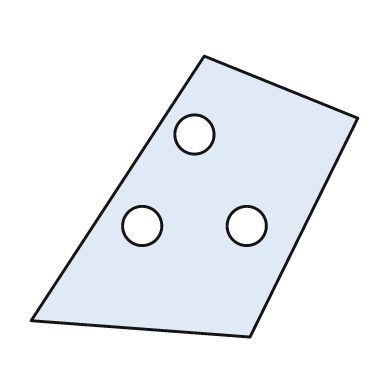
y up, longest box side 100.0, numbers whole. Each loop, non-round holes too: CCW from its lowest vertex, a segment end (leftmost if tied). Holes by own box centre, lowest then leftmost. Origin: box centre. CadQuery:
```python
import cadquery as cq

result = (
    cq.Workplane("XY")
    .moveTo(17.0, -43.0)
    .lineTo(50.0, 24.0)
    .lineTo(3.0, 43.0)
    .lineTo(-50.0, -38.0)
    .close()
    .moveTo(-16.0, -9.0)
    .circle(6.0)
    .moveTo(16.0, -9.0)
    .circle(6.0)
    .moveTo(0.0, 19.0)
    .circle(6.0)
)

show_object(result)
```